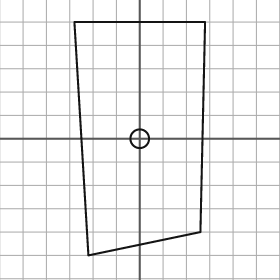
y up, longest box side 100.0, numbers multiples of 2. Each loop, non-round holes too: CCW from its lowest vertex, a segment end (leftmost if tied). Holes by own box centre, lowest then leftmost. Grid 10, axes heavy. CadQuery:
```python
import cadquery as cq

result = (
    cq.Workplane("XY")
    .moveTo(-22.0, -50.0)
    .lineTo(26.0, -40.0)
    .lineTo(28.0, 50.0)
    .lineTo(-28.0, 50.0)
    .close()
    .moveTo(0.0, 0.0)
    .circle(4.0)
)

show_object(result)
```